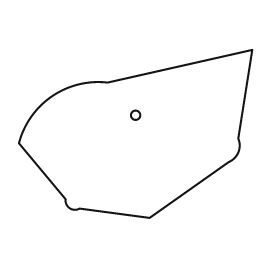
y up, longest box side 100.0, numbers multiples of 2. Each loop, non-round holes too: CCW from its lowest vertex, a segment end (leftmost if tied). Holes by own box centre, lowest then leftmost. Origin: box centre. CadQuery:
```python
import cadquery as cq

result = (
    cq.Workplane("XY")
    .moveTo(6.0, -36.0)
    .lineTo(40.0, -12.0)
    .threePointArc((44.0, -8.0), (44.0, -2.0))
    .lineTo(50.0, 36.0)
    .lineTo(-12.0, 22.0)
    .threePointArc((-36.0, 16.0), (-50.0, -4.0))
    .lineTo(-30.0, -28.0)
    .threePointArc((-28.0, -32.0), (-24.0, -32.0))
    .close()
    .moveTo(0.0, 8.0)
    .circle(2.0)
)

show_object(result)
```